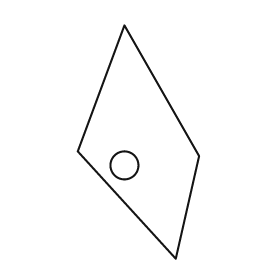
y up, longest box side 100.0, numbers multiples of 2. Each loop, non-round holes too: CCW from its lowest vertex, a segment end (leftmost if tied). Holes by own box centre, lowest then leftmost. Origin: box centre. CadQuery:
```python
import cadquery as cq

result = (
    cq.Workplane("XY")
    .moveTo(16.0, -50.0)
    .lineTo(26.0, -6.0)
    .lineTo(-6.0, 50.0)
    .lineTo(-26.0, -4.0)
    .close()
    .moveTo(-6.0, -10.0)
    .circle(6.0)
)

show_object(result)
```